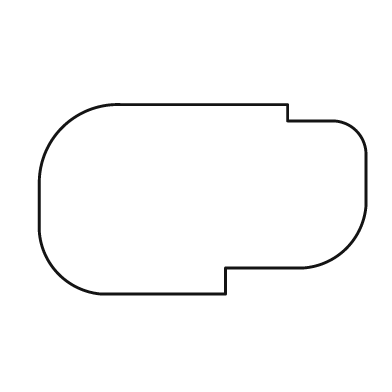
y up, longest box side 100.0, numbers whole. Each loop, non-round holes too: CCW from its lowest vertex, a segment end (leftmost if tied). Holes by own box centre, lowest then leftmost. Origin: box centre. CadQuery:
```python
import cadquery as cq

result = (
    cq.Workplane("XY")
    .moveTo(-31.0, -29.0)
    .lineTo(7.0, -29.0)
    .lineTo(7.0, -21.0)
    .lineTo(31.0, -21.0)
    .threePointArc((44.0, -15.0), (50.0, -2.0))
    .lineTo(50.0, 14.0)
    .threePointArc((47.0, 21.0), (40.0, 24.0))
    .lineTo(26.0, 24.0)
    .lineTo(26.0, 29.0)
    .lineTo(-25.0, 29.0)
    .threePointArc((-43.0, 22.0), (-50.0, 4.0))
    .lineTo(-50.0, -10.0)
    .threePointArc((-44.0, -23.0), (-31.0, -29.0))
    .close()
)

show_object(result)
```